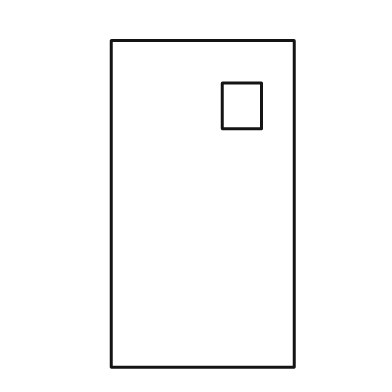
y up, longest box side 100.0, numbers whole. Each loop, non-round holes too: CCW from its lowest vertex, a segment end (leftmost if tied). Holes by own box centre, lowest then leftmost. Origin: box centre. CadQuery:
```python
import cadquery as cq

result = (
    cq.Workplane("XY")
    .moveTo(-28.0, -50.0)
    .lineTo(28.0, -50.0)
    .lineTo(28.0, 50.0)
    .lineTo(-28.0, 50.0)
    .close()
    .moveTo(6.0, 23.0)
    .lineTo(18.0, 23.0)
    .lineTo(18.0, 37.0)
    .lineTo(6.0, 37.0)
    .close()
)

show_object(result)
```